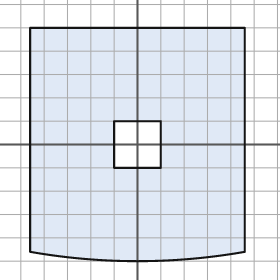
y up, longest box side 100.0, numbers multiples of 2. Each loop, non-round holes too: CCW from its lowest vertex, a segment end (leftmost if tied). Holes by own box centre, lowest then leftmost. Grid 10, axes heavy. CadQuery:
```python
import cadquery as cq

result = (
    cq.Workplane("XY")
    .moveTo(-46.0, -46.0)
    .threePointArc((0.0, -50.0), (46.0, -46.0))
    .lineTo(46.0, 50.0)
    .lineTo(-46.0, 50.0)
    .close()
    .moveTo(-10.0, -10.0)
    .lineTo(10.0, -10.0)
    .lineTo(10.0, 10.0)
    .lineTo(-10.0, 10.0)
    .close()
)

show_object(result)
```